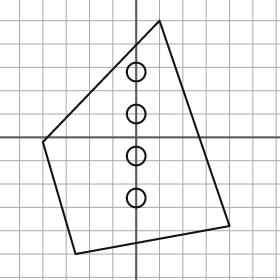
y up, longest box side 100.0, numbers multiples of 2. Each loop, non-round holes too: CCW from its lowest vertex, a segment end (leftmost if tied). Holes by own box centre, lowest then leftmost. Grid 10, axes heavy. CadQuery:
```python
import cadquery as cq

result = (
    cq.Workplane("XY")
    .moveTo(-26.0, -50.0)
    .lineTo(40.0, -38.0)
    .lineTo(10.0, 50.0)
    .lineTo(-40.0, -2.0)
    .close()
    .moveTo(0.0, -26.0)
    .circle(4.0)
    .moveTo(0.0, -8.0)
    .circle(4.0)
    .moveTo(0.0, 10.0)
    .circle(4.0)
    .moveTo(0.0, 28.0)
    .circle(4.0)
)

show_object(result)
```